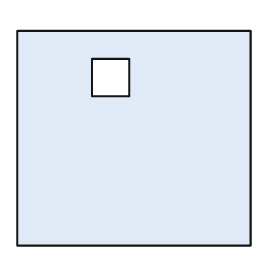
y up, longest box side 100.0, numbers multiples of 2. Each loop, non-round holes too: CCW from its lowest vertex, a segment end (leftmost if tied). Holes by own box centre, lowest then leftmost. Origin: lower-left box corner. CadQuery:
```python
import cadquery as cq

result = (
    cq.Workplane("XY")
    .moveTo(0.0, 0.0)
    .lineTo(100.0, 0.0)
    .lineTo(100.0, 92.0)
    .lineTo(0.0, 92.0)
    .close()
    .moveTo(32.0, 64.0)
    .lineTo(48.0, 64.0)
    .lineTo(48.0, 80.0)
    .lineTo(32.0, 80.0)
    .close()
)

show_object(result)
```